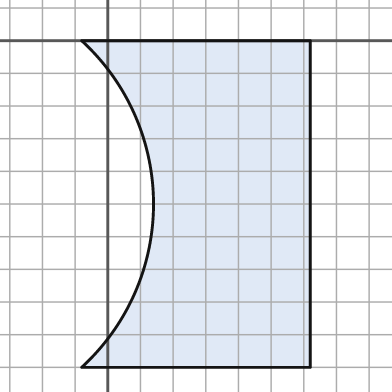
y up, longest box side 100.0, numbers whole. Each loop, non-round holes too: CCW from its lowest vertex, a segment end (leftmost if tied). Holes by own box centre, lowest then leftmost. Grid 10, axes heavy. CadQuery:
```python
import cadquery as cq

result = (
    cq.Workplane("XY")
    .moveTo(-8.0, -100.0)
    .lineTo(62.0, -100.0)
    .lineTo(62.0, 0.0)
    .lineTo(-8.0, 0.0)
    .threePointArc((14.0, -50.0), (-8.0, -100.0))
    .close()
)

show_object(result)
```